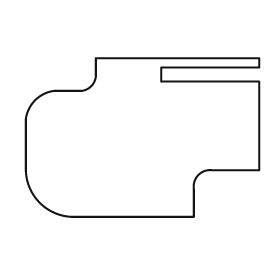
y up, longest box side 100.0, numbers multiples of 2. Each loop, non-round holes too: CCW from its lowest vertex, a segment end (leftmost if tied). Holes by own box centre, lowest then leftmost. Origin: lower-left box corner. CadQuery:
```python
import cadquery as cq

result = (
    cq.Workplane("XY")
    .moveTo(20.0, 0.0)
    .lineTo(72.0, 0.0)
    .lineTo(72.0, 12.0)
    .threePointArc((74.0, 18.0), (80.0, 20.0))
    .lineTo(100.0, 20.0)
    .lineTo(100.0, 58.0)
    .lineTo(58.0, 58.0)
    .lineTo(58.0, 64.0)
    .lineTo(100.0, 64.0)
    .lineTo(100.0, 68.0)
    .lineTo(30.0, 68.0)
    .lineTo(30.0, 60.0)
    .threePointArc((28.0, 56.0), (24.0, 54.0))
    .lineTo(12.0, 54.0)
    .threePointArc((4.0, 50.0), (0.0, 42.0))
    .lineTo(0.0, 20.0)
    .threePointArc((6.0, 6.0), (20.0, 0.0))
    .close()
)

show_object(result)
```